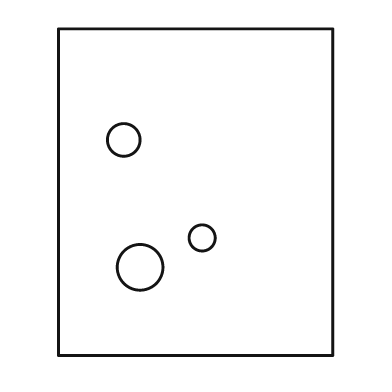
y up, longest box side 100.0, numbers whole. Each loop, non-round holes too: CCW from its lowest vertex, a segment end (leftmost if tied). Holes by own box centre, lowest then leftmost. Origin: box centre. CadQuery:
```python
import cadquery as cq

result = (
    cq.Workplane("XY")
    .moveTo(-42.0, -50.0)
    .lineTo(42.0, -50.0)
    .lineTo(42.0, 50.0)
    .lineTo(-42.0, 50.0)
    .close()
    .moveTo(-17.0, -23.0)
    .circle(7.0)
    .moveTo(2.0, -14.0)
    .circle(4.0)
    .moveTo(-22.0, 16.0)
    .circle(5.0)
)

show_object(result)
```